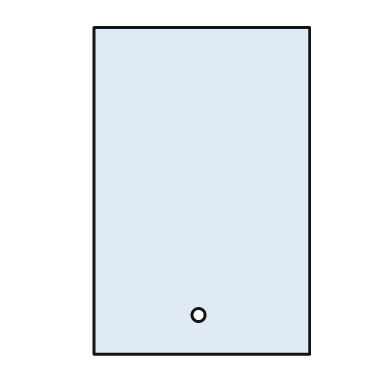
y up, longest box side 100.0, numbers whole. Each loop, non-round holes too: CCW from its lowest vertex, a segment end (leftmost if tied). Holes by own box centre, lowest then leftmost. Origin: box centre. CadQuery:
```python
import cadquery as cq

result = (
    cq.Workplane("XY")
    .moveTo(-33.0, -50.0)
    .lineTo(33.0, -50.0)
    .lineTo(33.0, 50.0)
    .lineTo(-33.0, 50.0)
    .close()
    .moveTo(-1.0, -38.0)
    .circle(2.0)
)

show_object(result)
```